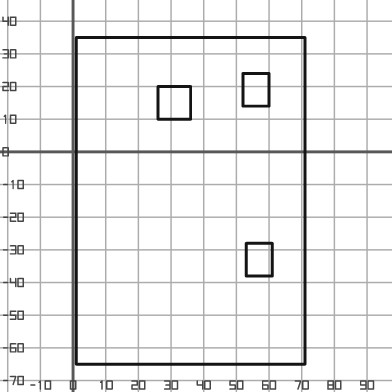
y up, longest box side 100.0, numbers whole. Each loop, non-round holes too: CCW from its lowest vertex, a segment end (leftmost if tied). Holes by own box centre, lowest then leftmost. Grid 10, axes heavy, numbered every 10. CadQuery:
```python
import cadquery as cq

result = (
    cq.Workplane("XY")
    .moveTo(1.0, -65.0)
    .lineTo(71.0, -65.0)
    .lineTo(71.0, 35.0)
    .lineTo(1.0, 35.0)
    .close()
    .moveTo(53.0, -38.0)
    .lineTo(61.0, -38.0)
    .lineTo(61.0, -28.0)
    .lineTo(53.0, -28.0)
    .close()
    .moveTo(26.0, 10.0)
    .lineTo(36.0, 10.0)
    .lineTo(36.0, 20.0)
    .lineTo(26.0, 20.0)
    .close()
    .moveTo(52.0, 14.0)
    .lineTo(60.0, 14.0)
    .lineTo(60.0, 24.0)
    .lineTo(52.0, 24.0)
    .close()
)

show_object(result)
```